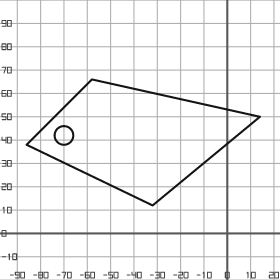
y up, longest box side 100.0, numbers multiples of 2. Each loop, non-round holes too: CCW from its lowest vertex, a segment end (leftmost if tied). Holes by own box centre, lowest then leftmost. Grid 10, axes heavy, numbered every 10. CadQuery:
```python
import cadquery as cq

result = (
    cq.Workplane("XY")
    .moveTo(-32.0, 12.0)
    .lineTo(14.0, 50.0)
    .lineTo(-58.0, 66.0)
    .lineTo(-86.0, 38.0)
    .close()
    .moveTo(-70.0, 42.0)
    .circle(4.0)
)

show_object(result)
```